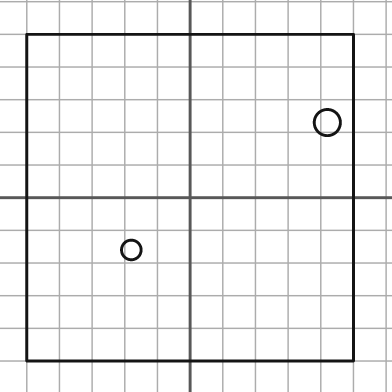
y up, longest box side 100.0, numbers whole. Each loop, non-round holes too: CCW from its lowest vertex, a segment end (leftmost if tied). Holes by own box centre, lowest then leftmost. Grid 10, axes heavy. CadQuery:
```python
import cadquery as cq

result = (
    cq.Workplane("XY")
    .moveTo(-50.0, -50.0)
    .lineTo(50.0, -50.0)
    .lineTo(50.0, 50.0)
    .lineTo(-50.0, 50.0)
    .close()
    .moveTo(-18.0, -16.0)
    .circle(3.0)
    .moveTo(42.0, 23.0)
    .circle(4.0)
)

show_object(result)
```